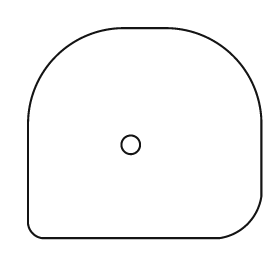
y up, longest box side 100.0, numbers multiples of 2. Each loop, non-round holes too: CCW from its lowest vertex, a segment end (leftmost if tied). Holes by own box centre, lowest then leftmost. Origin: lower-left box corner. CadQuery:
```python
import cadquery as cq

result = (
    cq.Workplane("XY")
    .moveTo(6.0, 0.0)
    .lineTo(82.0, 0.0)
    .threePointArc((94.0, 6.0), (100.0, 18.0))
    .lineTo(100.0, 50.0)
    .threePointArc((88.0, 78.0), (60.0, 90.0))
    .lineTo(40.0, 90.0)
    .threePointArc((12.0, 78.0), (0.0, 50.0))
    .lineTo(0.0, 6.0)
    .threePointArc((2.0, 2.0), (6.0, 0.0))
    .close()
    .moveTo(44.0, 40.0)
    .circle(4.0)
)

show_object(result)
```